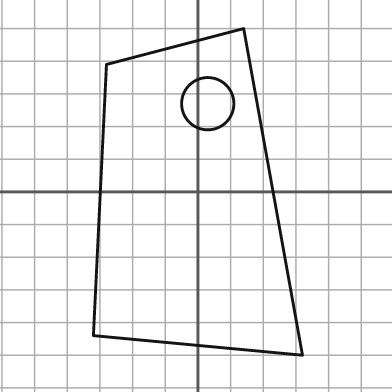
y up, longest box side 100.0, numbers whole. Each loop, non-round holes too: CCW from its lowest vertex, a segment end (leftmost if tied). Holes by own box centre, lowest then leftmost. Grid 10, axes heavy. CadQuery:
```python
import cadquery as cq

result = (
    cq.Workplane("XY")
    .moveTo(32.0, -50.0)
    .lineTo(14.0, 50.0)
    .lineTo(-28.0, 39.0)
    .lineTo(-32.0, -44.0)
    .close()
    .moveTo(3.0, 27.0)
    .circle(8.0)
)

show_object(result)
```